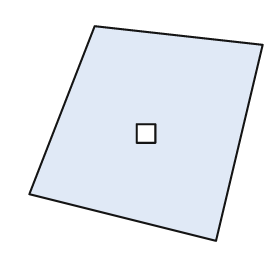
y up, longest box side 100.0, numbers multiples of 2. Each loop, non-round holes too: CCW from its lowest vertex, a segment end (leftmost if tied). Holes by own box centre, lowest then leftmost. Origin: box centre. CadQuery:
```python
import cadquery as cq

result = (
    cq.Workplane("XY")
    .moveTo(30.0, -46.0)
    .lineTo(50.0, 38.0)
    .lineTo(-22.0, 46.0)
    .lineTo(-50.0, -26.0)
    .close()
    .moveTo(-4.0, -4.0)
    .lineTo(4.0, -4.0)
    .lineTo(4.0, 4.0)
    .lineTo(-4.0, 4.0)
    .close()
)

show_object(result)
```